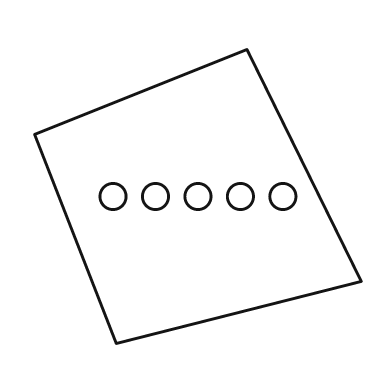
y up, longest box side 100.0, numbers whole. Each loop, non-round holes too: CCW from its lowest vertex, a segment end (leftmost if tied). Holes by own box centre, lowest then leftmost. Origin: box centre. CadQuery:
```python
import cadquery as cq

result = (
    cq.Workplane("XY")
    .moveTo(-25.0, -45.0)
    .lineTo(50.0, -26.0)
    .lineTo(15.0, 45.0)
    .lineTo(-50.0, 19.0)
    .close()
    .moveTo(-26.0, 0.0)
    .circle(4.0)
    .moveTo(-13.0, 0.0)
    .circle(4.0)
    .moveTo(0.0, 0.0)
    .circle(4.0)
    .moveTo(13.0, 0.0)
    .circle(4.0)
    .moveTo(26.0, 0.0)
    .circle(4.0)
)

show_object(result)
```